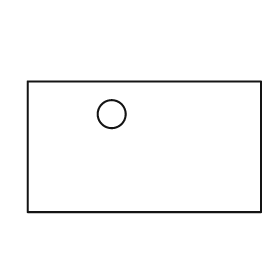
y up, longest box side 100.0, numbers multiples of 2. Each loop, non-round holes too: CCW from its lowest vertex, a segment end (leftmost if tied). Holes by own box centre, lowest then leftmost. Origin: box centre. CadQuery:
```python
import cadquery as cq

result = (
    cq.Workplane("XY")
    .moveTo(-50.0, -28.0)
    .lineTo(50.0, -28.0)
    .lineTo(50.0, 28.0)
    .lineTo(-50.0, 28.0)
    .close()
    .moveTo(-14.0, 14.0)
    .circle(6.0)
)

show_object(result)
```